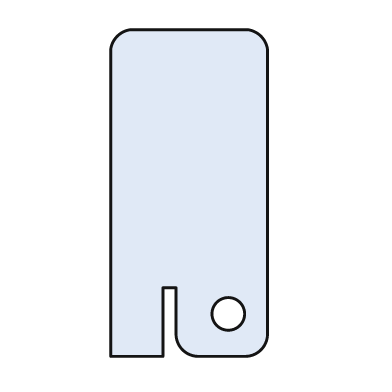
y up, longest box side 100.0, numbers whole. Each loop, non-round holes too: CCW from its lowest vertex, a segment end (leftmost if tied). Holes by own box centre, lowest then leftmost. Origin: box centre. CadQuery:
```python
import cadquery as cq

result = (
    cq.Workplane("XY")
    .moveTo(-24.0, -50.0)
    .lineTo(-8.0, -50.0)
    .lineTo(-8.0, -29.0)
    .lineTo(-4.0, -29.0)
    .lineTo(-4.0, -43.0)
    .threePointArc((-2.0, -48.0), (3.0, -50.0))
    .lineTo(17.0, -50.0)
    .threePointArc((22.0, -48.0), (24.0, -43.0))
    .lineTo(24.0, 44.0)
    .threePointArc((22.0, 48.0), (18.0, 50.0))
    .lineTo(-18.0, 50.0)
    .threePointArc((-22.0, 48.0), (-24.0, 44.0))
    .close()
    .moveTo(12.0, -37.0)
    .circle(5.0)
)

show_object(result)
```